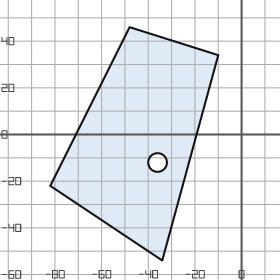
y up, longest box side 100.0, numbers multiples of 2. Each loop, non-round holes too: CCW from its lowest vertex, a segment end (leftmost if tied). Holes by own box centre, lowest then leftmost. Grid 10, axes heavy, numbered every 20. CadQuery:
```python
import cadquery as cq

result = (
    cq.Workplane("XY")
    .moveTo(-34.0, -54.0)
    .lineTo(-10.0, 34.0)
    .lineTo(-48.0, 46.0)
    .lineTo(-82.0, -22.0)
    .close()
    .moveTo(-36.0, -12.0)
    .circle(4.0)
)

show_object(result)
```